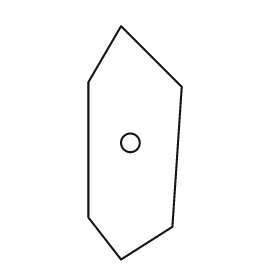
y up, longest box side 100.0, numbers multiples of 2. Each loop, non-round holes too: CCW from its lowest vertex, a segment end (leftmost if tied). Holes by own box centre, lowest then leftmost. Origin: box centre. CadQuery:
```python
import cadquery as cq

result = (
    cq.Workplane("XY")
    .moveTo(-6.0, -50.0)
    .lineTo(16.0, -36.0)
    .lineTo(20.0, 24.0)
    .lineTo(-6.0, 50.0)
    .lineTo(-20.0, 26.0)
    .lineTo(-20.0, -32.0)
    .close()
    .moveTo(-2.0, 0.0)
    .circle(4.0)
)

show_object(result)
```